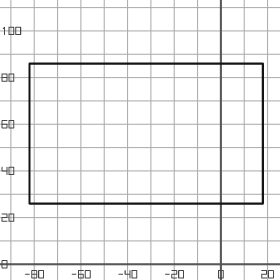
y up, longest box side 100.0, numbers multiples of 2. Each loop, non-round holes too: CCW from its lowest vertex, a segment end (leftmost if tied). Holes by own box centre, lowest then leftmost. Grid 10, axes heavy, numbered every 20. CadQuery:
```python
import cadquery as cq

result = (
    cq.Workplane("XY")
    .moveTo(-82.0, 26.0)
    .lineTo(18.0, 26.0)
    .lineTo(18.0, 86.0)
    .lineTo(-82.0, 86.0)
    .close()
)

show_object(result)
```